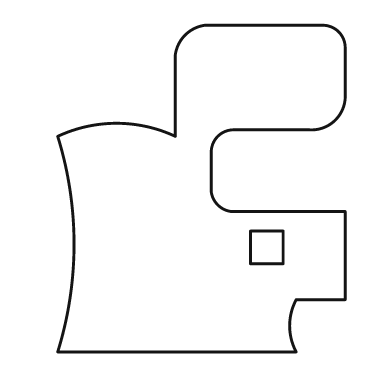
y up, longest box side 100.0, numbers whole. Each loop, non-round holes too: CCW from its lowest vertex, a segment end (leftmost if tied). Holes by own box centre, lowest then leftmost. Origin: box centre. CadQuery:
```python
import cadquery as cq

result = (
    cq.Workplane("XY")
    .moveTo(-44.0, -50.0)
    .lineTo(29.0, -50.0)
    .threePointArc((27.0, -42.0), (29.0, -34.0))
    .lineTo(44.0, -34.0)
    .lineTo(44.0, -7.0)
    .lineTo(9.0, -7.0)
    .threePointArc((5.0, -5.0), (3.0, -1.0))
    .lineTo(3.0, 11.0)
    .threePointArc((5.0, 16.0), (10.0, 18.0))
    .lineTo(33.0, 18.0)
    .threePointArc((41.0, 21.0), (44.0, 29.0))
    .lineTo(44.0, 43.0)
    .threePointArc((42.0, 48.0), (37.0, 50.0))
    .lineTo(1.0, 50.0)
    .threePointArc((-5.0, 47.0), (-8.0, 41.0))
    .lineTo(-8.0, 16.0)
    .threePointArc((-26.0, 20.0), (-44.0, 16.0))
    .threePointArc((-39.0, -17.0), (-44.0, -50.0))
    .close()
    .moveTo(15.0, -23.0)
    .lineTo(25.0, -23.0)
    .lineTo(25.0, -13.0)
    .lineTo(15.0, -13.0)
    .close()
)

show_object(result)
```